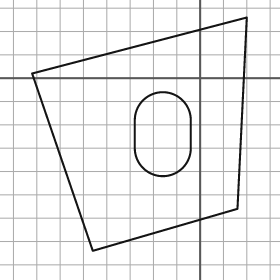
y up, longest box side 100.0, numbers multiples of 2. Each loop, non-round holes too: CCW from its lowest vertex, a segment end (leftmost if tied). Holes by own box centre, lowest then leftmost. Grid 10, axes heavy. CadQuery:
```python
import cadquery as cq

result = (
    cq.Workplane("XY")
    .moveTo(-46.0, -74.0)
    .lineTo(16.0, -56.0)
    .lineTo(20.0, 26.0)
    .lineTo(-72.0, 2.0)
    .close()
    .moveTo(-28.0, -30.0)
    .threePointArc((-16.0, -42.0), (-4.0, -30.0))
    .lineTo(-4.0, -18.0)
    .threePointArc((-16.0, -6.0), (-28.0, -18.0))
    .close()
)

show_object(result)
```